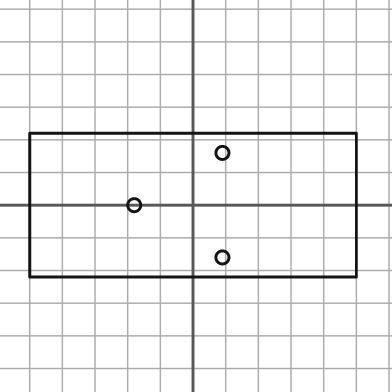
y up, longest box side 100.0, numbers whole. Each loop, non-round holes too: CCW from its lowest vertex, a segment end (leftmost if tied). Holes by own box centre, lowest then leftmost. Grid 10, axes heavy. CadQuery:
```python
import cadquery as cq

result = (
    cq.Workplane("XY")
    .moveTo(-50.0, -22.0)
    .lineTo(50.0, -22.0)
    .lineTo(50.0, 22.0)
    .lineTo(-50.0, 22.0)
    .close()
    .moveTo(9.0, -16.0)
    .circle(2.0)
    .moveTo(-18.0, 0.0)
    .circle(2.0)
    .moveTo(9.0, 16.0)
    .circle(2.0)
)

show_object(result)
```